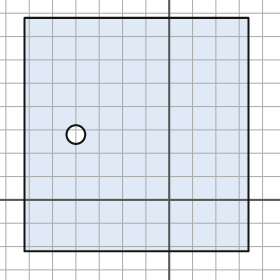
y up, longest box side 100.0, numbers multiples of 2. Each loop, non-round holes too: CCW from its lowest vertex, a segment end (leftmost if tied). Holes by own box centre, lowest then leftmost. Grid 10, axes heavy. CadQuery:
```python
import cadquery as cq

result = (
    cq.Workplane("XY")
    .moveTo(-62.0, -22.0)
    .lineTo(34.0, -22.0)
    .lineTo(34.0, 78.0)
    .lineTo(-62.0, 78.0)
    .close()
    .moveTo(-40.0, 28.0)
    .circle(4.0)
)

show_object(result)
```